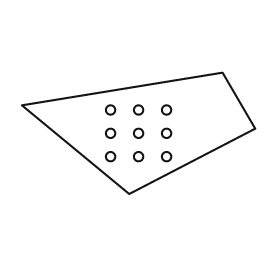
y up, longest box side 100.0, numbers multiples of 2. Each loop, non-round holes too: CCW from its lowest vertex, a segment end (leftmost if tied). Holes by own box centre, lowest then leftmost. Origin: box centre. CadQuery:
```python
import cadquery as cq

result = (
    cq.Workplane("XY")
    .moveTo(-4.0, -26.0)
    .lineTo(50.0, 2.0)
    .lineTo(36.0, 26.0)
    .lineTo(-50.0, 12.0)
    .close()
    .moveTo(-12.0, -10.0)
    .circle(2.0)
    .moveTo(0.0, -10.0)
    .circle(2.0)
    .moveTo(12.0, -10.0)
    .circle(2.0)
    .moveTo(-12.0, 0.0)
    .circle(2.0)
    .moveTo(0.0, 0.0)
    .circle(2.0)
    .moveTo(12.0, 0.0)
    .circle(2.0)
    .moveTo(-12.0, 10.0)
    .circle(2.0)
    .moveTo(0.0, 10.0)
    .circle(2.0)
    .moveTo(12.0, 10.0)
    .circle(2.0)
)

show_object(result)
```